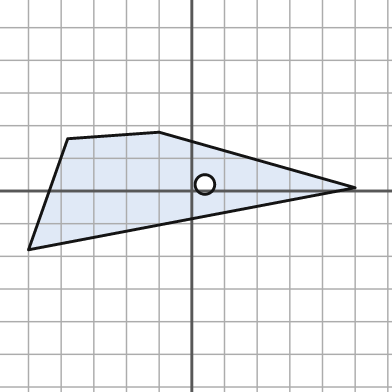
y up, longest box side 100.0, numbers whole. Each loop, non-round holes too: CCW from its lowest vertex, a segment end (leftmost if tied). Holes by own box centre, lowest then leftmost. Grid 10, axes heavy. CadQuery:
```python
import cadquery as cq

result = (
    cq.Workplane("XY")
    .moveTo(-50.0, -18.0)
    .lineTo(50.0, 1.0)
    .lineTo(-10.0, 18.0)
    .lineTo(-38.0, 16.0)
    .close()
    .moveTo(4.0, 2.0)
    .circle(3.0)
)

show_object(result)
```